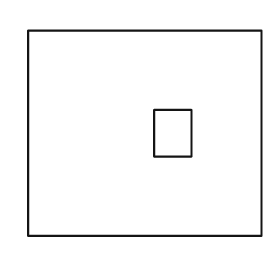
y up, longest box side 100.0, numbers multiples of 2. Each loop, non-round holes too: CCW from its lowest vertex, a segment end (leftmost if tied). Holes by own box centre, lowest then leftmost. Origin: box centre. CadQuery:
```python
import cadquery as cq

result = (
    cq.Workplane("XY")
    .moveTo(-50.0, -44.0)
    .lineTo(50.0, -44.0)
    .lineTo(50.0, 44.0)
    .lineTo(-50.0, 44.0)
    .close()
    .moveTo(4.0, -10.0)
    .lineTo(20.0, -10.0)
    .lineTo(20.0, 10.0)
    .lineTo(4.0, 10.0)
    .close()
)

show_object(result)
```